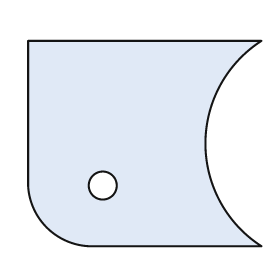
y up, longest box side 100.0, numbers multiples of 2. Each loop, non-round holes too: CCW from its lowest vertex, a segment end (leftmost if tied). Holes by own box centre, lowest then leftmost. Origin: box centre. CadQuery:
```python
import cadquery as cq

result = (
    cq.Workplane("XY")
    .moveTo(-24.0, -44.0)
    .lineTo(50.0, -44.0)
    .threePointArc((26.0, 0.0), (50.0, 44.0))
    .lineTo(-50.0, 44.0)
    .lineTo(-50.0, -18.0)
    .threePointArc((-42.0, -36.0), (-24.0, -44.0))
    .close()
    .moveTo(-18.0, -18.0)
    .circle(6.0)
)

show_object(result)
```